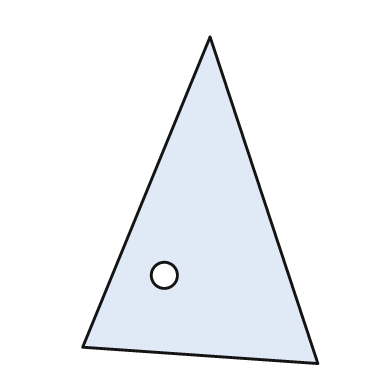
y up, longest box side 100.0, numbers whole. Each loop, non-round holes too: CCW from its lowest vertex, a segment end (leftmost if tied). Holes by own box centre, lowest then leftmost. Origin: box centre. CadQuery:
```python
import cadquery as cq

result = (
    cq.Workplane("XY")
    .moveTo(36.0, -50.0)
    .lineTo(3.0, 50.0)
    .lineTo(-36.0, -45.0)
    .close()
    .moveTo(-11.0, -23.0)
    .circle(4.0)
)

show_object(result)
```